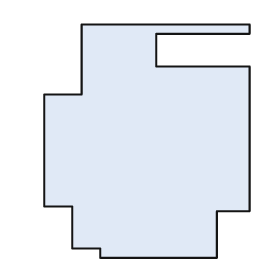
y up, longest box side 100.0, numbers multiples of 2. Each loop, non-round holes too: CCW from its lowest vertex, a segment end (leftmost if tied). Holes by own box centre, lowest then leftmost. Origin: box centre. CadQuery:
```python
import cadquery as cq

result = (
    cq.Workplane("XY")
    .moveTo(-20.0, -50.0)
    .lineTo(30.0, -50.0)
    .lineTo(30.0, -30.0)
    .lineTo(44.0, -30.0)
    .lineTo(44.0, 32.0)
    .lineTo(4.0, 32.0)
    .lineTo(4.0, 46.0)
    .lineTo(44.0, 46.0)
    .lineTo(44.0, 50.0)
    .lineTo(-28.0, 50.0)
    .lineTo(-28.0, 20.0)
    .lineTo(-44.0, 20.0)
    .lineTo(-44.0, -28.0)
    .lineTo(-32.0, -28.0)
    .lineTo(-32.0, -46.0)
    .lineTo(-20.0, -46.0)
    .close()
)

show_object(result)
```